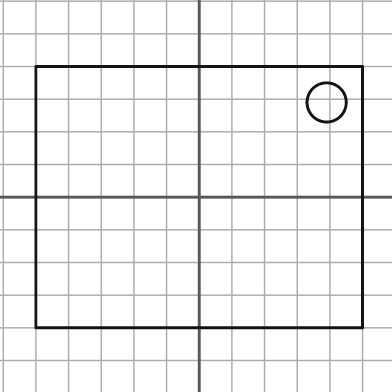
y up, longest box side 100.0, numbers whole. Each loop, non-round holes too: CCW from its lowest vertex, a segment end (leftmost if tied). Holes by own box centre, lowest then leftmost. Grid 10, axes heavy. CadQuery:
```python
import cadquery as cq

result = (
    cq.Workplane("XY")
    .moveTo(-50.0, -40.0)
    .lineTo(50.0, -40.0)
    .lineTo(50.0, 40.0)
    .lineTo(-50.0, 40.0)
    .close()
    .moveTo(39.0, 29.0)
    .circle(6.0)
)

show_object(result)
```